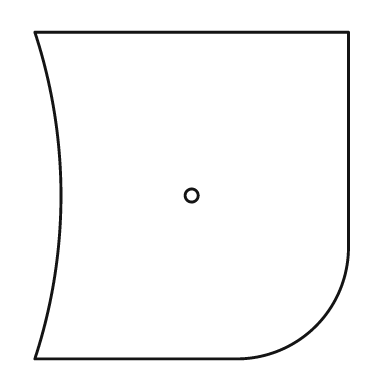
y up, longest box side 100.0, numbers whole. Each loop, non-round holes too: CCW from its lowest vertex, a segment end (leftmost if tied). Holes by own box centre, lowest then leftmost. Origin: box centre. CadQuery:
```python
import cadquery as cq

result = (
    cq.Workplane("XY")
    .moveTo(-48.0, -50.0)
    .lineTo(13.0, -50.0)
    .threePointArc((38.0, -40.0), (48.0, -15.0))
    .lineTo(48.0, 50.0)
    .lineTo(-48.0, 50.0)
    .threePointArc((-40.0, 0.0), (-48.0, -50.0))
    .close()
    .moveTo(0.0, 0.0)
    .circle(2.0)
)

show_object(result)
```